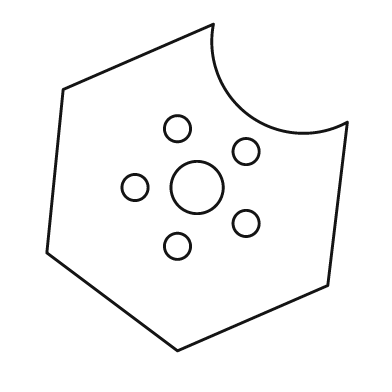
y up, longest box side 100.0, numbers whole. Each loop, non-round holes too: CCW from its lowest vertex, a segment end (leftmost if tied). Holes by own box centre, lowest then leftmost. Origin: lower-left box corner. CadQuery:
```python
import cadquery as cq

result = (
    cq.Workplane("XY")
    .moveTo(40.0, 0.0)
    .lineTo(86.0, 20.0)
    .lineTo(92.0, 70.0)
    .threePointArc((62.0, 72.0), (51.0, 100.0))
    .lineTo(5.0, 80.0)
    .lineTo(0.0, 30.0)
    .close()
    .moveTo(40.0, 32.0)
    .circle(4.0)
    .moveTo(61.0, 39.0)
    .circle(4.0)
    .moveTo(27.0, 50.0)
    .circle(4.0)
    .moveTo(46.0, 50.0)
    .circle(8.0)
    .moveTo(61.0, 61.0)
    .circle(4.0)
    .moveTo(40.0, 68.0)
    .circle(4.0)
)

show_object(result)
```